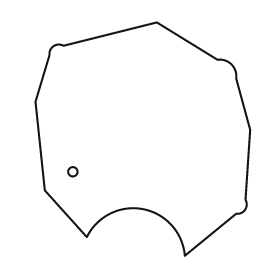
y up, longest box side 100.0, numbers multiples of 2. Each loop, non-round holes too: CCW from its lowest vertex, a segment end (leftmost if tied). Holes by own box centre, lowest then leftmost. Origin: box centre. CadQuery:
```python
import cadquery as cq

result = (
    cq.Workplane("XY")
    .moveTo(18.0, -50.0)
    .lineTo(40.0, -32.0)
    .threePointArc((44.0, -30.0), (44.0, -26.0))
    .lineTo(46.0, 4.0)
    .lineTo(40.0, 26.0)
    .threePointArc((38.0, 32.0), (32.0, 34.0))
    .lineTo(6.0, 50.0)
    .lineTo(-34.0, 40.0)
    .threePointArc((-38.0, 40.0), (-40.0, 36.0))
    .lineTo(-46.0, 16.0)
    .lineTo(-42.0, -22.0)
    .lineTo(-24.0, -42.0)
    .threePointArc((0.0, -30.0), (18.0, -50.0))
    .close()
    .moveTo(-30.0, -14.0)
    .circle(2.0)
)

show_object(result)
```